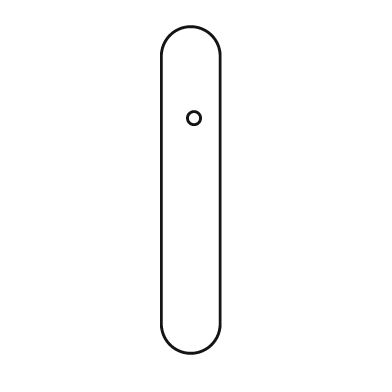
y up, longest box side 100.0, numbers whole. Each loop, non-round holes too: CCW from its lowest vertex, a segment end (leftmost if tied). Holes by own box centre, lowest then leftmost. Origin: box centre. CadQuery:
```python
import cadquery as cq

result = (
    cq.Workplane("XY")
    .moveTo(-9.0, -41.0)
    .threePointArc((0.0, -50.0), (9.0, -41.0))
    .lineTo(9.0, 41.0)
    .threePointArc((0.0, 50.0), (-9.0, 41.0))
    .close()
    .moveTo(1.0, 22.0)
    .circle(2.0)
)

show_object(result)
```